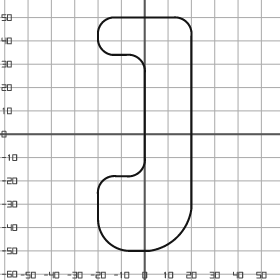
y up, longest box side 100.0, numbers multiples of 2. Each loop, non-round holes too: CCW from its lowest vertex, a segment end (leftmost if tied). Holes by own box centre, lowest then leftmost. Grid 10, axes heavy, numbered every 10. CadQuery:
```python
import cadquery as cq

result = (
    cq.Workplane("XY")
    .moveTo(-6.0, -50.0)
    .lineTo(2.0, -50.0)
    .threePointArc((14.0, -44.0), (20.0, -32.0))
    .lineTo(20.0, 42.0)
    .threePointArc((18.0, 48.0), (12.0, 50.0))
    .lineTo(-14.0, 50.0)
    .threePointArc((-18.0, 48.0), (-20.0, 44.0))
    .lineTo(-20.0, 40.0)
    .threePointArc((-18.0, 36.0), (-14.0, 34.0))
    .lineTo(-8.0, 34.0)
    .threePointArc((-2.0, 32.0), (0.0, 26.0))
    .lineTo(0.0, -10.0)
    .threePointArc((-2.0, -16.0), (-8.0, -18.0))
    .lineTo(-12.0, -18.0)
    .threePointArc((-18.0, -20.0), (-20.0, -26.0))
    .lineTo(-20.0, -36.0)
    .threePointArc((-16.0, -46.0), (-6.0, -50.0))
    .close()
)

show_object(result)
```